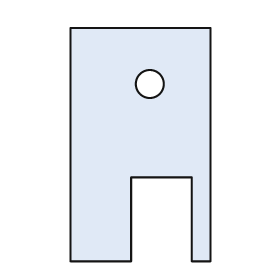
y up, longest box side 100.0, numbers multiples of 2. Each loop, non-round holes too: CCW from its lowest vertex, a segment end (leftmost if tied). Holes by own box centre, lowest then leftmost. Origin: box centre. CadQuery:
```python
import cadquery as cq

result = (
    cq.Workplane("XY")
    .moveTo(-30.0, -50.0)
    .lineTo(-4.0, -50.0)
    .lineTo(-4.0, -14.0)
    .lineTo(22.0, -14.0)
    .lineTo(22.0, -50.0)
    .lineTo(30.0, -50.0)
    .lineTo(30.0, 50.0)
    .lineTo(-30.0, 50.0)
    .close()
    .moveTo(4.0, 26.0)
    .circle(6.0)
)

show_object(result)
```